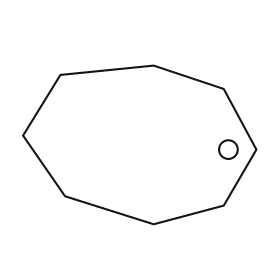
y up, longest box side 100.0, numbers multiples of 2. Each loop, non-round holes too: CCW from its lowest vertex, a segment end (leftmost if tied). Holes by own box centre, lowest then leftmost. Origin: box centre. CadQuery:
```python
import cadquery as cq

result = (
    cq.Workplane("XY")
    .moveTo(6.0, -34.0)
    .lineTo(36.0, -26.0)
    .lineTo(50.0, -2.0)
    .lineTo(36.0, 24.0)
    .lineTo(6.0, 34.0)
    .lineTo(-34.0, 30.0)
    .lineTo(-50.0, 4.0)
    .lineTo(-32.0, -22.0)
    .close()
    .moveTo(38.0, -2.0)
    .circle(4.0)
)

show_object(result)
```